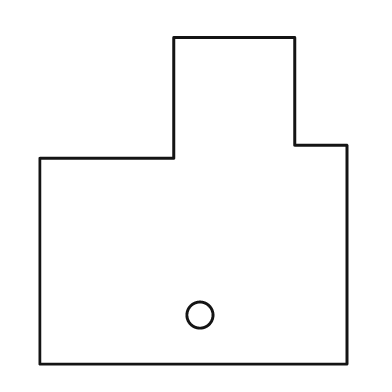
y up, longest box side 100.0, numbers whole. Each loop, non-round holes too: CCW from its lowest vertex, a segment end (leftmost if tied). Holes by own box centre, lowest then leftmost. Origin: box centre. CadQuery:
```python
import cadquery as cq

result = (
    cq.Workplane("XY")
    .moveTo(-47.0, -50.0)
    .lineTo(47.0, -50.0)
    .lineTo(47.0, 17.0)
    .lineTo(31.0, 17.0)
    .lineTo(31.0, 50.0)
    .lineTo(-6.0, 50.0)
    .lineTo(-6.0, 13.0)
    .lineTo(-47.0, 13.0)
    .close()
    .moveTo(2.0, -35.0)
    .circle(4.0)
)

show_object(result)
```